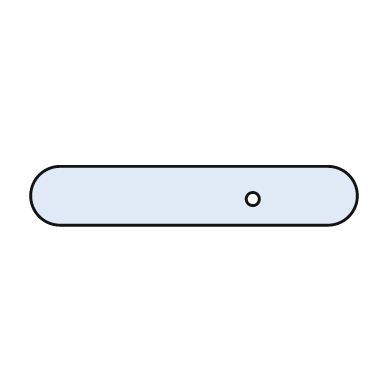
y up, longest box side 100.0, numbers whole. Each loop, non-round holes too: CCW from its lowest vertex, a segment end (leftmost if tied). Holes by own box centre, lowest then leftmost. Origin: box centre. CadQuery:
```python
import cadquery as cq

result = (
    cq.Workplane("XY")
    .moveTo(-41.0, -9.0)
    .lineTo(41.0, -9.0)
    .threePointArc((50.0, 0.0), (41.0, 9.0))
    .lineTo(-41.0, 9.0)
    .threePointArc((-50.0, 0.0), (-41.0, -9.0))
    .close()
    .moveTo(18.0, -1.0)
    .circle(2.0)
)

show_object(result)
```